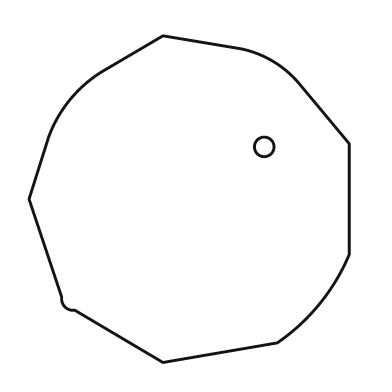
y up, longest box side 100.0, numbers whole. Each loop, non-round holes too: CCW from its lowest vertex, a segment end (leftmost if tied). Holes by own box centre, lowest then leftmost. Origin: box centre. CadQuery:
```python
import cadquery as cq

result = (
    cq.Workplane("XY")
    .moveTo(-8.0, -50.0)
    .lineTo(27.0, -44.0)
    .threePointArc((40.0, -32.0), (49.0, -17.0))
    .lineTo(49.0, 17.0)
    .lineTo(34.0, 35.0)
    .threePointArc((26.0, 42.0), (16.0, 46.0))
    .lineTo(-8.0, 50.0)
    .lineTo(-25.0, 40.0)
    .threePointArc((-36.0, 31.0), (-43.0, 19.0))
    .lineTo(-49.0, 0.0)
    .lineTo(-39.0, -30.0)
    .threePointArc((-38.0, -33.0), (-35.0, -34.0))
    .close()
    .moveTo(23.0, 16.0)
    .circle(3.0)
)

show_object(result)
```